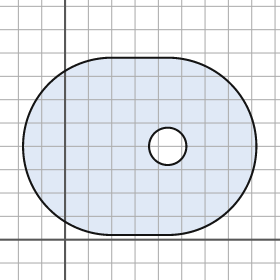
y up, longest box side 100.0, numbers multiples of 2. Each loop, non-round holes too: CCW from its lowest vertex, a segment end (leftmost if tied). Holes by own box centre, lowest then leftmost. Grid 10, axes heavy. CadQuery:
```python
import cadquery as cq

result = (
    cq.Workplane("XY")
    .moveTo(20.0, 2.0)
    .lineTo(44.0, 2.0)
    .threePointArc((82.0, 40.0), (44.0, 78.0))
    .lineTo(20.0, 78.0)
    .threePointArc((-18.0, 40.0), (20.0, 2.0))
    .close()
    .moveTo(44.0, 40.0)
    .circle(8.0)
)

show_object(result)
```